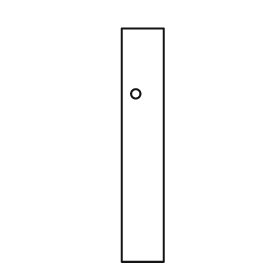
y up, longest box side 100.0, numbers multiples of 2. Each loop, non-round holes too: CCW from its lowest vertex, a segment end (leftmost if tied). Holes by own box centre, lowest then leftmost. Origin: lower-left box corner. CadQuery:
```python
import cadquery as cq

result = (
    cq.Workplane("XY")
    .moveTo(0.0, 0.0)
    .lineTo(18.0, 0.0)
    .lineTo(18.0, 100.0)
    .lineTo(0.0, 100.0)
    .close()
    .moveTo(6.0, 72.0)
    .circle(2.0)
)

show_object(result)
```